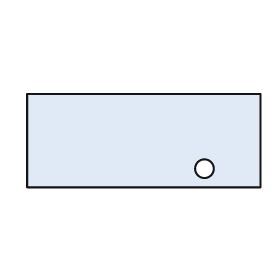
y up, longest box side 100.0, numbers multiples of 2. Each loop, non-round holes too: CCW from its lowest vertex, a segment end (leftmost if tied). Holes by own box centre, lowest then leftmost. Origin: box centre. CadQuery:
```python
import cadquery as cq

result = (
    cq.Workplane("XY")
    .moveTo(-50.0, -20.0)
    .lineTo(50.0, -20.0)
    .lineTo(50.0, 20.0)
    .lineTo(-50.0, 20.0)
    .close()
    .moveTo(26.0, -12.0)
    .circle(4.0)
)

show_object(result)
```